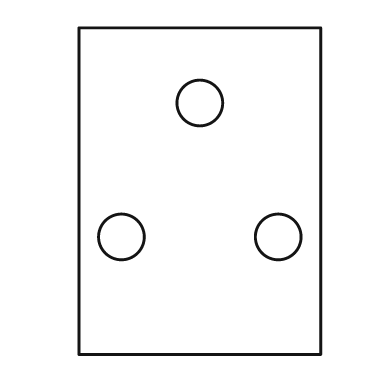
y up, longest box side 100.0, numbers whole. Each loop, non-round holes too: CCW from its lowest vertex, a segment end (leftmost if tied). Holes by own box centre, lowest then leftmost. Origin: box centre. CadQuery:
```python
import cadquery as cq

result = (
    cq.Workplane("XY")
    .moveTo(-37.0, -50.0)
    .lineTo(37.0, -50.0)
    .lineTo(37.0, 50.0)
    .lineTo(-37.0, 50.0)
    .close()
    .moveTo(-24.0, -14.0)
    .circle(7.0)
    .moveTo(24.0, -14.0)
    .circle(7.0)
    .moveTo(0.0, 27.0)
    .circle(7.0)
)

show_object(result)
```